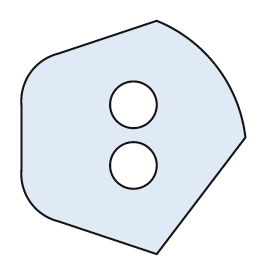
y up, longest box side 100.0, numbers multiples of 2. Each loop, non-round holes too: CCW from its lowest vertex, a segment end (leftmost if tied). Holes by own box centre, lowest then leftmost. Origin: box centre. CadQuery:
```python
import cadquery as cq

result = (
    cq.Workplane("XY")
    .moveTo(10.0, -50.0)
    .lineTo(48.0, 0.0)
    .threePointArc((36.0, 30.0), (10.0, 50.0))
    .lineTo(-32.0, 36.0)
    .threePointArc((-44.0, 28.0), (-48.0, 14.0))
    .lineTo(-48.0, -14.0)
    .threePointArc((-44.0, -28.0), (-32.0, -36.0))
    .close()
    .moveTo(0.0, -12.0)
    .circle(10.0)
    .moveTo(0.0, 14.0)
    .circle(10.0)
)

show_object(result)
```